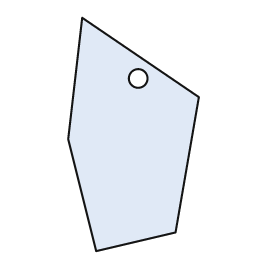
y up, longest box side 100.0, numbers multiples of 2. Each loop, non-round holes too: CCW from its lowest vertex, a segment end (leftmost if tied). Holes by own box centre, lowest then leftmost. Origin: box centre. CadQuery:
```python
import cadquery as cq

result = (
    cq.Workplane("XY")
    .moveTo(-16.0, -50.0)
    .lineTo(18.0, -42.0)
    .lineTo(28.0, 16.0)
    .lineTo(-22.0, 50.0)
    .lineTo(-28.0, -2.0)
    .close()
    .moveTo(2.0, 24.0)
    .circle(4.0)
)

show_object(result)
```